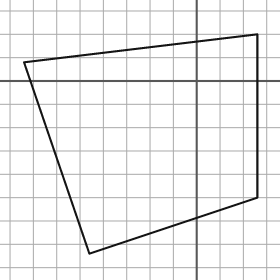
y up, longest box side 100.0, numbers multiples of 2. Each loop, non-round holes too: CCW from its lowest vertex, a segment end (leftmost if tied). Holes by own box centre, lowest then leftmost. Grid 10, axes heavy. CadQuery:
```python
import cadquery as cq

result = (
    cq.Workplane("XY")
    .moveTo(-46.0, -74.0)
    .lineTo(26.0, -50.0)
    .lineTo(26.0, 20.0)
    .lineTo(-74.0, 8.0)
    .close()
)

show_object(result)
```